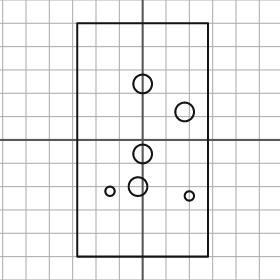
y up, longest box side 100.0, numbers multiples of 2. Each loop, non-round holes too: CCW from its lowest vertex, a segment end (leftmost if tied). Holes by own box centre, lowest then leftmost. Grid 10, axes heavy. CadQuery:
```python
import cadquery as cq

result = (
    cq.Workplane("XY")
    .moveTo(-28.0, -50.0)
    .lineTo(28.0, -50.0)
    .lineTo(28.0, 50.0)
    .lineTo(-28.0, 50.0)
    .close()
    .moveTo(20.0, -24.0)
    .circle(2.0)
    .moveTo(-14.0, -22.0)
    .circle(2.0)
    .moveTo(-2.0, -20.0)
    .circle(4.0)
    .moveTo(0.0, -6.0)
    .circle(4.0)
    .moveTo(18.0, 12.0)
    .circle(4.0)
    .moveTo(0.0, 24.0)
    .circle(4.0)
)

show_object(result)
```